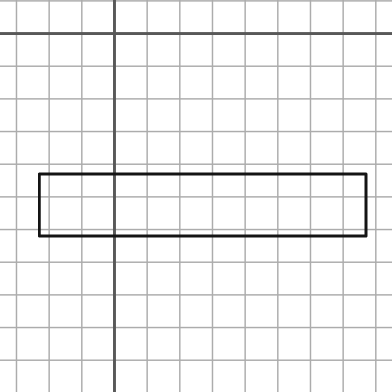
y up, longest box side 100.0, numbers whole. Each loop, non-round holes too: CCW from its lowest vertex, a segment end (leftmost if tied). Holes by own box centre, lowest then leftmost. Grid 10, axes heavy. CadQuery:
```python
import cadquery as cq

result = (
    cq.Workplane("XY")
    .moveTo(-23.0, -62.0)
    .lineTo(77.0, -62.0)
    .lineTo(77.0, -43.0)
    .lineTo(-23.0, -43.0)
    .close()
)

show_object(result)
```